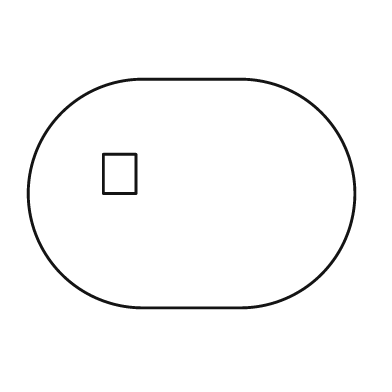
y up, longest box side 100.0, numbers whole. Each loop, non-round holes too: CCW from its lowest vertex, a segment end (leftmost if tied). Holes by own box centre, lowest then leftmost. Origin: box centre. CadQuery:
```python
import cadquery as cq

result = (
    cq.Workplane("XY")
    .moveTo(-15.0, -35.0)
    .lineTo(15.0, -35.0)
    .threePointArc((50.0, 0.0), (15.0, 35.0))
    .lineTo(-15.0, 35.0)
    .threePointArc((-50.0, 0.0), (-15.0, -35.0))
    .close()
    .moveTo(-27.0, 0.0)
    .lineTo(-17.0, 0.0)
    .lineTo(-17.0, 12.0)
    .lineTo(-27.0, 12.0)
    .close()
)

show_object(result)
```